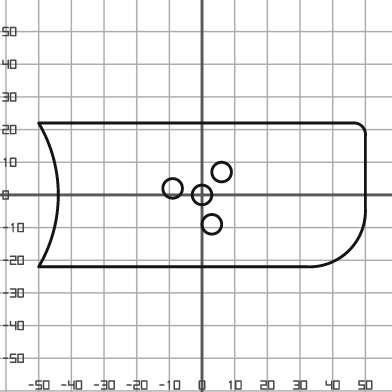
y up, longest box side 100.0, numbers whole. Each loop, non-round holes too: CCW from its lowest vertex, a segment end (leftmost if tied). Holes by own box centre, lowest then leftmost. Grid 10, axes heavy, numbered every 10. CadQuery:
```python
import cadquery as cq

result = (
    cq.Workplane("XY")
    .moveTo(-50.0, -22.0)
    .lineTo(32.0, -22.0)
    .threePointArc((45.0, -17.0), (50.0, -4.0))
    .lineTo(50.0, 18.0)
    .threePointArc((49.0, 21.0), (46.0, 22.0))
    .lineTo(-50.0, 22.0)
    .threePointArc((-44.0, 0.0), (-50.0, -22.0))
    .close()
    .moveTo(3.0, -9.0)
    .circle(3.0)
    .moveTo(0.0, 0.0)
    .circle(3.0)
    .moveTo(-9.0, 2.0)
    .circle(3.0)
    .moveTo(6.0, 7.0)
    .circle(3.0)
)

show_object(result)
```